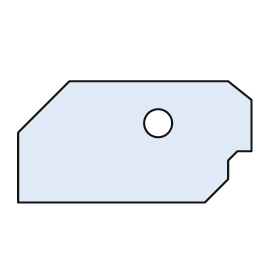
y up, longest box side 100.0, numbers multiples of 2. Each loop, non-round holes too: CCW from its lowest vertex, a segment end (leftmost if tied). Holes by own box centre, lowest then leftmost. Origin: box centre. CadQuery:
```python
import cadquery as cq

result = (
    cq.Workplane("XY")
    .moveTo(-50.0, -26.0)
    .lineTo(30.0, -26.0)
    .lineTo(40.0, -16.0)
    .lineTo(40.0, -8.0)
    .lineTo(44.0, -4.0)
    .lineTo(50.0, -4.0)
    .lineTo(50.0, 18.0)
    .lineTo(40.0, 26.0)
    .lineTo(-28.0, 26.0)
    .lineTo(-50.0, 4.0)
    .close()
    .moveTo(10.0, 8.0)
    .circle(6.0)
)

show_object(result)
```